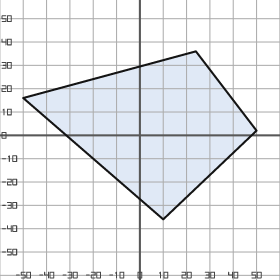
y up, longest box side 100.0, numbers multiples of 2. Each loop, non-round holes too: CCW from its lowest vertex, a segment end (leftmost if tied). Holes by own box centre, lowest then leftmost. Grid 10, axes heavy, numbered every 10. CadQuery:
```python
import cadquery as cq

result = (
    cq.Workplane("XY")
    .moveTo(10.0, -36.0)
    .lineTo(50.0, 2.0)
    .lineTo(24.0, 36.0)
    .lineTo(-50.0, 16.0)
    .close()
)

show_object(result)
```